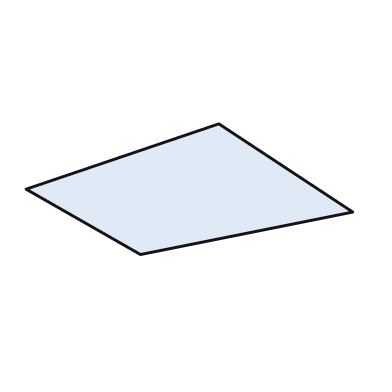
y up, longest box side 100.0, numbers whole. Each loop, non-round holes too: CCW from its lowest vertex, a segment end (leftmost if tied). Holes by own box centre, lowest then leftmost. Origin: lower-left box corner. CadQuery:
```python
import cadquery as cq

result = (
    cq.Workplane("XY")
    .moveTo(35.0, 0.0)
    .lineTo(100.0, 13.0)
    .lineTo(59.0, 40.0)
    .lineTo(0.0, 20.0)
    .close()
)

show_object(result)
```